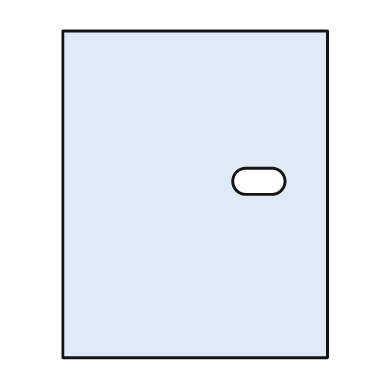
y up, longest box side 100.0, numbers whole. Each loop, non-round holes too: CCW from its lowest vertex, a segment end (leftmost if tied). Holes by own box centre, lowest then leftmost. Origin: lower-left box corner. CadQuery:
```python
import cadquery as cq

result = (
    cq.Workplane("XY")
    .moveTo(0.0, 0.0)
    .lineTo(81.0, 0.0)
    .lineTo(81.0, 100.0)
    .lineTo(0.0, 100.0)
    .close()
    .moveTo(56.0, 50.0)
    .lineTo(64.0, 50.0)
    .threePointArc((68.0, 54.0), (64.0, 58.0))
    .lineTo(56.0, 58.0)
    .threePointArc((52.0, 54.0), (56.0, 50.0))
    .close()
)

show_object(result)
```